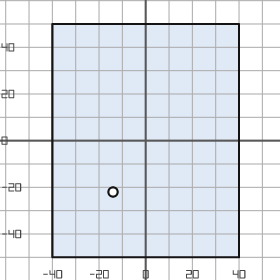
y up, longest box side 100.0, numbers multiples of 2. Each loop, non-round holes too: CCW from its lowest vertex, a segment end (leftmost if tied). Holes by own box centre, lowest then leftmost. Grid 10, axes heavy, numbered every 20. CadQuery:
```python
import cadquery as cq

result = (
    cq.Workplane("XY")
    .moveTo(-40.0, -50.0)
    .lineTo(40.0, -50.0)
    .lineTo(40.0, 50.0)
    .lineTo(-40.0, 50.0)
    .close()
    .moveTo(-14.0, -22.0)
    .circle(2.0)
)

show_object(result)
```